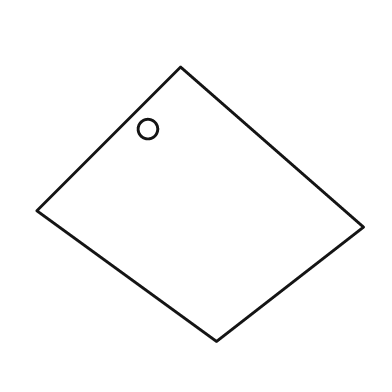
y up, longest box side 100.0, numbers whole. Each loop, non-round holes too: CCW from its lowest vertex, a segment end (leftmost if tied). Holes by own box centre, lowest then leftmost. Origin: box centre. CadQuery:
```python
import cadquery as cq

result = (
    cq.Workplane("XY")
    .moveTo(5.0, -42.0)
    .lineTo(50.0, -7.0)
    .lineTo(-6.0, 42.0)
    .lineTo(-50.0, -2.0)
    .close()
    .moveTo(-16.0, 23.0)
    .circle(3.0)
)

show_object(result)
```